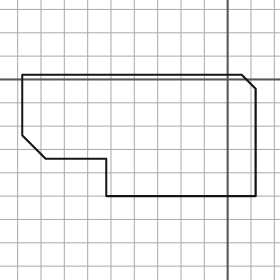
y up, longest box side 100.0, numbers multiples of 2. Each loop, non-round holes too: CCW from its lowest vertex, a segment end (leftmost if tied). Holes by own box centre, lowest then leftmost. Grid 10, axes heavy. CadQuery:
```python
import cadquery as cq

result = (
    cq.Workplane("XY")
    .moveTo(-52.0, -50.0)
    .lineTo(12.0, -50.0)
    .lineTo(12.0, -4.0)
    .lineTo(6.0, 2.0)
    .lineTo(-88.0, 2.0)
    .lineTo(-88.0, -24.0)
    .lineTo(-78.0, -34.0)
    .lineTo(-52.0, -34.0)
    .close()
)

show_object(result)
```